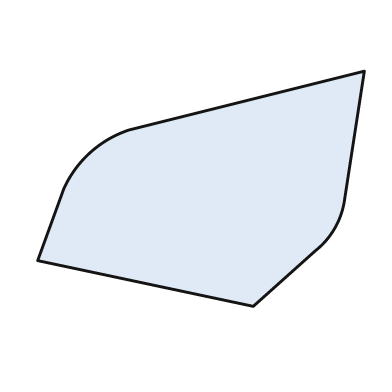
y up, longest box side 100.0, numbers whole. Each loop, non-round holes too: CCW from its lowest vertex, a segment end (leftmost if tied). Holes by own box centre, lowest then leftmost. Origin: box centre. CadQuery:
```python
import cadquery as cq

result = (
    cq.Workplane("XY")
    .moveTo(16.0, -36.0)
    .lineTo(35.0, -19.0)
    .threePointArc((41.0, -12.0), (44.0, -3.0))
    .lineTo(50.0, 36.0)
    .lineTo(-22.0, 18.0)
    .threePointArc((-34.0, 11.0), (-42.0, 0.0))
    .lineTo(-50.0, -22.0)
    .close()
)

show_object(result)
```